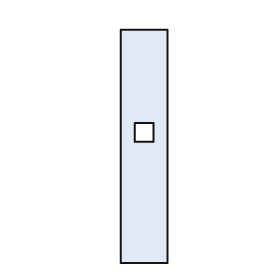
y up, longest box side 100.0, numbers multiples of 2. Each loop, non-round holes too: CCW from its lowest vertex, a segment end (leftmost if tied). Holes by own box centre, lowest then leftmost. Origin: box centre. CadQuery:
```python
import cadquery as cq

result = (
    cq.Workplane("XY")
    .moveTo(-10.0, -50.0)
    .lineTo(10.0, -50.0)
    .lineTo(10.0, 50.0)
    .lineTo(-10.0, 50.0)
    .close()
    .moveTo(-4.0, 2.0)
    .lineTo(4.0, 2.0)
    .lineTo(4.0, 10.0)
    .lineTo(-4.0, 10.0)
    .close()
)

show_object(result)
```